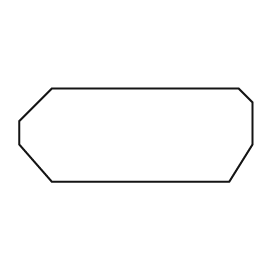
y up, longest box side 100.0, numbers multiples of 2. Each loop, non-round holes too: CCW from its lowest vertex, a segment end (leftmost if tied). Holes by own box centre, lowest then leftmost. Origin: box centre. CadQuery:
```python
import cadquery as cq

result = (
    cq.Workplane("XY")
    .moveTo(-36.0, -20.0)
    .lineTo(40.0, -20.0)
    .lineTo(50.0, -4.0)
    .lineTo(50.0, 14.0)
    .lineTo(44.0, 20.0)
    .lineTo(-36.0, 20.0)
    .lineTo(-50.0, 6.0)
    .lineTo(-50.0, -4.0)
    .close()
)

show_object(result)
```